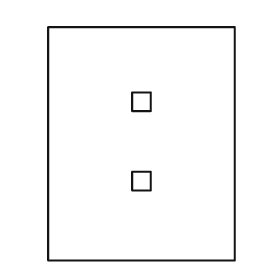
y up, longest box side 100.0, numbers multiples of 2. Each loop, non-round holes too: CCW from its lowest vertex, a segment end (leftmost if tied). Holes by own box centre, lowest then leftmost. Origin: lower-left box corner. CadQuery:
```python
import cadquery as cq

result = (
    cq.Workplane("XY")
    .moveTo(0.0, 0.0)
    .lineTo(80.0, 0.0)
    .lineTo(80.0, 100.0)
    .lineTo(0.0, 100.0)
    .close()
    .moveTo(36.0, 30.0)
    .lineTo(44.0, 30.0)
    .lineTo(44.0, 38.0)
    .lineTo(36.0, 38.0)
    .close()
    .moveTo(36.0, 64.0)
    .lineTo(44.0, 64.0)
    .lineTo(44.0, 72.0)
    .lineTo(36.0, 72.0)
    .close()
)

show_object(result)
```